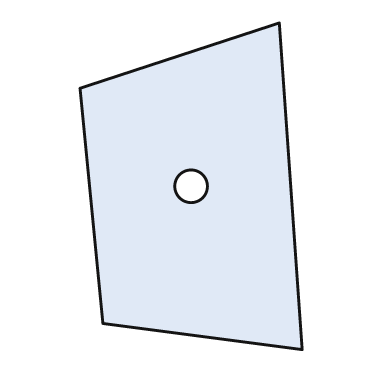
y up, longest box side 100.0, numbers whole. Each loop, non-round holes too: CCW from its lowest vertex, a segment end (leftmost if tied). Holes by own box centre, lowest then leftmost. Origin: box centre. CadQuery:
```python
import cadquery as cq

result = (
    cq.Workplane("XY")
    .moveTo(34.0, -50.0)
    .lineTo(27.0, 50.0)
    .lineTo(-34.0, 30.0)
    .lineTo(-27.0, -42.0)
    .close()
    .moveTo(0.0, 0.0)
    .circle(5.0)
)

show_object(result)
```